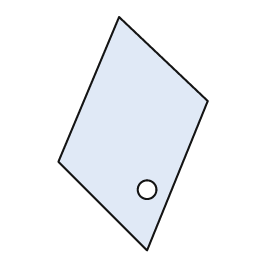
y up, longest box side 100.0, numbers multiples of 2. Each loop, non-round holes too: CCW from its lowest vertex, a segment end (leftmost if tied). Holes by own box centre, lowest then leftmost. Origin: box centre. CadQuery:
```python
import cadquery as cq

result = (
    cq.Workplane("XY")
    .moveTo(6.0, -50.0)
    .lineTo(32.0, 14.0)
    .lineTo(-6.0, 50.0)
    .lineTo(-32.0, -12.0)
    .close()
    .moveTo(6.0, -24.0)
    .circle(4.0)
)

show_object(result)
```